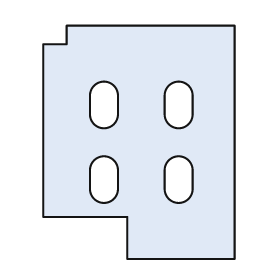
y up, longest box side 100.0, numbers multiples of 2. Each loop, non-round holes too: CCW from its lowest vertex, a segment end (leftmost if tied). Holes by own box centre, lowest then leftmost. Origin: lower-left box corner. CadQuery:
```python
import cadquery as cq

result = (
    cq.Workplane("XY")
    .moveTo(36.0, 0.0)
    .lineTo(82.0, 0.0)
    .lineTo(82.0, 100.0)
    .lineTo(10.0, 100.0)
    .lineTo(10.0, 92.0)
    .lineTo(0.0, 92.0)
    .lineTo(0.0, 18.0)
    .lineTo(36.0, 18.0)
    .close()
    .moveTo(20.0, 30.0)
    .threePointArc((26.0, 24.0), (32.0, 30.0))
    .lineTo(32.0, 38.0)
    .threePointArc((26.0, 44.0), (20.0, 38.0))
    .close()
    .moveTo(52.0, 30.0)
    .threePointArc((58.0, 24.0), (64.0, 30.0))
    .lineTo(64.0, 38.0)
    .threePointArc((58.0, 44.0), (52.0, 38.0))
    .close()
    .moveTo(20.0, 62.0)
    .threePointArc((26.0, 56.0), (32.0, 62.0))
    .lineTo(32.0, 70.0)
    .threePointArc((26.0, 76.0), (20.0, 70.0))
    .close()
    .moveTo(52.0, 62.0)
    .threePointArc((58.0, 56.0), (64.0, 62.0))
    .lineTo(64.0, 70.0)
    .threePointArc((58.0, 76.0), (52.0, 70.0))
    .close()
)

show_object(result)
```